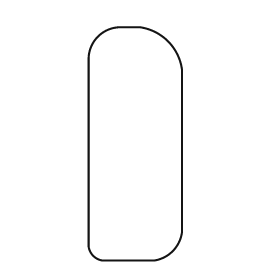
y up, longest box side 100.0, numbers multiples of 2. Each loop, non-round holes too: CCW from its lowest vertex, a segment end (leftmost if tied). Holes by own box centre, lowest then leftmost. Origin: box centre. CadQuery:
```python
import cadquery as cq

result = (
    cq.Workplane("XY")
    .moveTo(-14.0, -50.0)
    .lineTo(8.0, -50.0)
    .threePointArc((16.0, -46.0), (20.0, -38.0))
    .lineTo(20.0, 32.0)
    .threePointArc((14.0, 44.0), (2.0, 50.0))
    .lineTo(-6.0, 50.0)
    .threePointArc((-16.0, 46.0), (-20.0, 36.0))
    .lineTo(-20.0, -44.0)
    .threePointArc((-18.0, -48.0), (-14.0, -50.0))
    .close()
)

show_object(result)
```